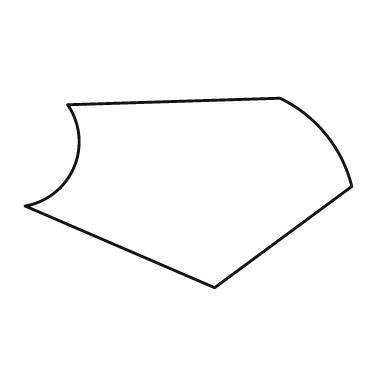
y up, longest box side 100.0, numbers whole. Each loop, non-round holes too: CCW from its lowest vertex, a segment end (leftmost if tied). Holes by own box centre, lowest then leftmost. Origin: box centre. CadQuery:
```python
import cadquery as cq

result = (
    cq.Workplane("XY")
    .moveTo(8.0, -29.0)
    .lineTo(50.0, 2.0)
    .threePointArc((42.0, 18.0), (28.0, 29.0))
    .lineTo(-37.0, 27.0)
    .threePointArc((-35.0, 8.0), (-50.0, -4.0))
    .close()
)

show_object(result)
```